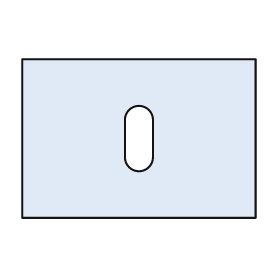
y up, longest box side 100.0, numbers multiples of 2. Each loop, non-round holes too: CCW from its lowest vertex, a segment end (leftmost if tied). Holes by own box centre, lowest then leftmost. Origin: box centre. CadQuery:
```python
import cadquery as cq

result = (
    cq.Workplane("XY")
    .moveTo(-50.0, -34.0)
    .lineTo(50.0, -34.0)
    .lineTo(50.0, 34.0)
    .lineTo(-50.0, 34.0)
    .close()
    .moveTo(-6.0, -8.0)
    .threePointArc((0.0, -14.0), (6.0, -8.0))
    .lineTo(6.0, 8.0)
    .threePointArc((0.0, 14.0), (-6.0, 8.0))
    .close()
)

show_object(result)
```